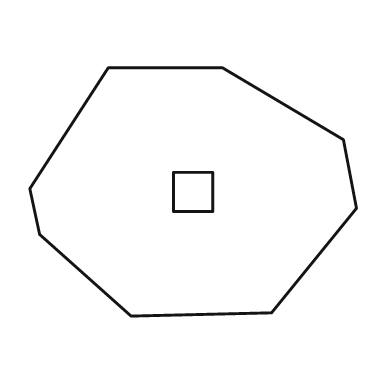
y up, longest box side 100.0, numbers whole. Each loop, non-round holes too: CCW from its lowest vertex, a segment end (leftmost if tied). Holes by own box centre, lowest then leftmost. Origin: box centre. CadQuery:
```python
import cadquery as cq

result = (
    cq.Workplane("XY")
    .moveTo(-19.0, -38.0)
    .lineTo(24.0, -37.0)
    .lineTo(50.0, -5.0)
    .lineTo(46.0, 16.0)
    .lineTo(9.0, 38.0)
    .lineTo(-26.0, 38.0)
    .lineTo(-50.0, 1.0)
    .lineTo(-47.0, -13.0)
    .close()
    .moveTo(-6.0, -6.0)
    .lineTo(6.0, -6.0)
    .lineTo(6.0, 6.0)
    .lineTo(-6.0, 6.0)
    .close()
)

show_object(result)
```